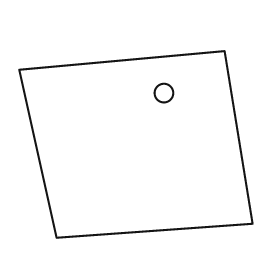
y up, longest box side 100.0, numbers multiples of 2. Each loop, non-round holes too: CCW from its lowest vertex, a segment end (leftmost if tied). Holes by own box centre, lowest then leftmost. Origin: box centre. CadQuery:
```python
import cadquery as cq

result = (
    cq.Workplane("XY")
    .moveTo(-34.0, -40.0)
    .lineTo(50.0, -34.0)
    .lineTo(38.0, 40.0)
    .lineTo(-50.0, 32.0)
    .close()
    .moveTo(12.0, 22.0)
    .circle(4.0)
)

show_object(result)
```